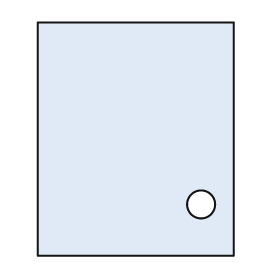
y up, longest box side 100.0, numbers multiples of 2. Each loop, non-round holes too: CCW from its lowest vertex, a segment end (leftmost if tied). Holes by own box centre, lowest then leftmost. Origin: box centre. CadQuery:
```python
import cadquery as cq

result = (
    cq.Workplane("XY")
    .moveTo(-42.0, -50.0)
    .lineTo(42.0, -50.0)
    .lineTo(42.0, 50.0)
    .lineTo(-42.0, 50.0)
    .close()
    .moveTo(28.0, -28.0)
    .circle(6.0)
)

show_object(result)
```